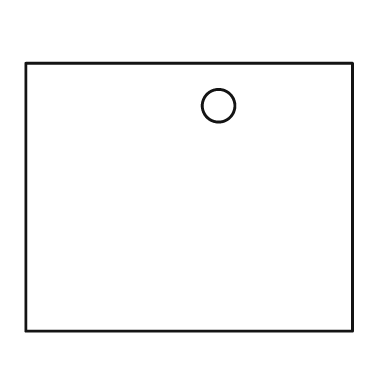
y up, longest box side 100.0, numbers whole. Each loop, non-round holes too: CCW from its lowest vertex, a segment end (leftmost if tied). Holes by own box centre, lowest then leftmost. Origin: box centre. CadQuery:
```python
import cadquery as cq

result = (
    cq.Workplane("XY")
    .moveTo(-50.0, -41.0)
    .lineTo(50.0, -41.0)
    .lineTo(50.0, 41.0)
    .lineTo(-50.0, 41.0)
    .close()
    .moveTo(9.0, 28.0)
    .circle(5.0)
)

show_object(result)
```